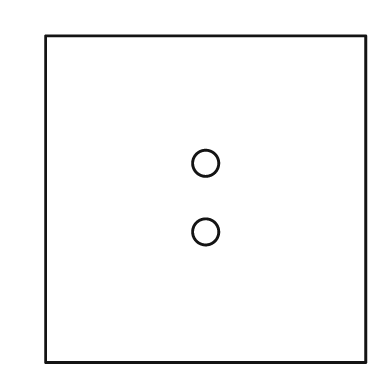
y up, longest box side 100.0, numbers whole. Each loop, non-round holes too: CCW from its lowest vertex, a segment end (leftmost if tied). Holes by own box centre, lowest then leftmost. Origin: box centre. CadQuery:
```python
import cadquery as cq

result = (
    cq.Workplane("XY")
    .moveTo(-49.0, -50.0)
    .lineTo(49.0, -50.0)
    .lineTo(49.0, 50.0)
    .lineTo(-49.0, 50.0)
    .close()
    .moveTo(0.0, -10.0)
    .circle(4.0)
    .moveTo(0.0, 11.0)
    .circle(4.0)
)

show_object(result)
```